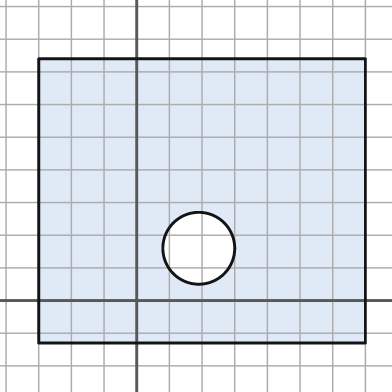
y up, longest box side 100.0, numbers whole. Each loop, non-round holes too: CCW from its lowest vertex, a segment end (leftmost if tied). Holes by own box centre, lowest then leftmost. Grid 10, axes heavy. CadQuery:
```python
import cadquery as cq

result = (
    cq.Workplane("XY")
    .moveTo(-30.0, -13.0)
    .lineTo(70.0, -13.0)
    .lineTo(70.0, 74.0)
    .lineTo(-30.0, 74.0)
    .close()
    .moveTo(19.0, 16.0)
    .circle(11.0)
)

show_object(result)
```